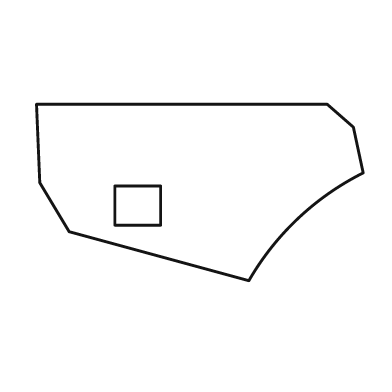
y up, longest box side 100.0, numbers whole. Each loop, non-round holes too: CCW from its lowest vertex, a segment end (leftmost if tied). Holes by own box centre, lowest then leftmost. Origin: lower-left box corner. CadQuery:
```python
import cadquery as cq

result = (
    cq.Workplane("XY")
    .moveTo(65.0, 0.0)
    .threePointArc((80.0, 19.0), (100.0, 33.0))
    .lineTo(97.0, 47.0)
    .lineTo(89.0, 54.0)
    .lineTo(0.0, 54.0)
    .lineTo(1.0, 30.0)
    .lineTo(10.0, 15.0)
    .close()
    .moveTo(24.0, 17.0)
    .lineTo(38.0, 17.0)
    .lineTo(38.0, 29.0)
    .lineTo(24.0, 29.0)
    .close()
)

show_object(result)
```